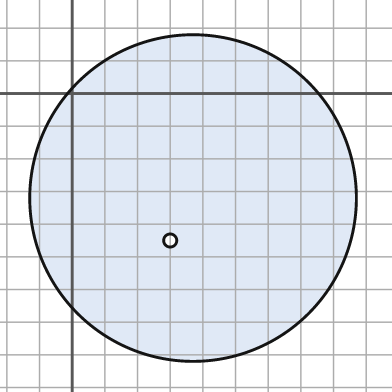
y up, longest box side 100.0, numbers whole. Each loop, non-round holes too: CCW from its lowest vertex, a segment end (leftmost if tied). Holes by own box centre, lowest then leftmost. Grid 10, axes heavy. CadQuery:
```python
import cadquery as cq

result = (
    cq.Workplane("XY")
    .moveTo(37.0, -32.0)
    .circle(50.0)
    .moveTo(30.0, -45.0)
    .circle(2.0)
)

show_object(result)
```